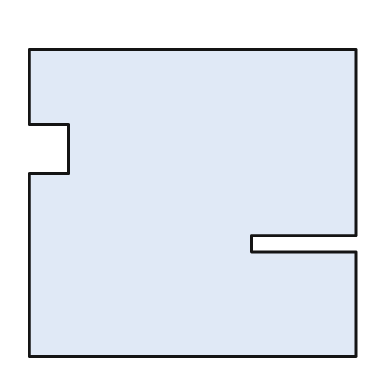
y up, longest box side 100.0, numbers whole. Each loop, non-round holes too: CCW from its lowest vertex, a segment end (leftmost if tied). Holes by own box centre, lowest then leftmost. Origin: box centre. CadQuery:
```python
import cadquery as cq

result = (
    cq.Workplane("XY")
    .moveTo(-50.0, -47.0)
    .lineTo(50.0, -47.0)
    .lineTo(50.0, -15.0)
    .lineTo(18.0, -15.0)
    .lineTo(18.0, -10.0)
    .lineTo(50.0, -10.0)
    .lineTo(50.0, 47.0)
    .lineTo(-50.0, 47.0)
    .lineTo(-50.0, 24.0)
    .lineTo(-38.0, 24.0)
    .lineTo(-38.0, 9.0)
    .lineTo(-50.0, 9.0)
    .close()
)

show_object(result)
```